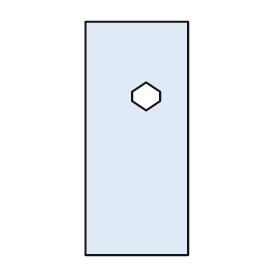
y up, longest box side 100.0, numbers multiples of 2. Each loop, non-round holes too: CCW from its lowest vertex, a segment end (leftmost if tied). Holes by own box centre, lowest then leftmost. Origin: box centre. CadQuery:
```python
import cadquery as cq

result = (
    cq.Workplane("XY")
    .moveTo(-22.0, -50.0)
    .lineTo(22.0, -50.0)
    .lineTo(22.0, 50.0)
    .lineTo(-22.0, 50.0)
    .close()
    .moveTo(4.0, 12.0)
    .lineTo(10.0, 16.0)
    .lineTo(10.0, 20.0)
    .lineTo(4.0, 24.0)
    .lineTo(-2.0, 20.0)
    .lineTo(-2.0, 16.0)
    .close()
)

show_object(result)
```